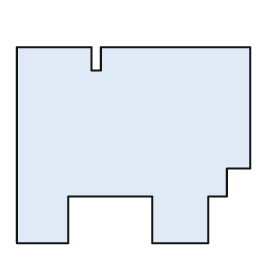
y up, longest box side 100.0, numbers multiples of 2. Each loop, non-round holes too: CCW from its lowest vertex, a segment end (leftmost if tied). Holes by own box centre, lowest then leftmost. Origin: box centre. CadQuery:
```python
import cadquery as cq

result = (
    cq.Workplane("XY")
    .moveTo(-50.0, -42.0)
    .lineTo(-28.0, -42.0)
    .lineTo(-28.0, -22.0)
    .lineTo(8.0, -22.0)
    .lineTo(8.0, -42.0)
    .lineTo(32.0, -42.0)
    .lineTo(32.0, -22.0)
    .lineTo(40.0, -22.0)
    .lineTo(40.0, -10.0)
    .lineTo(50.0, -10.0)
    .lineTo(50.0, 42.0)
    .lineTo(-14.0, 42.0)
    .lineTo(-14.0, 32.0)
    .lineTo(-18.0, 32.0)
    .lineTo(-18.0, 42.0)
    .lineTo(-50.0, 42.0)
    .close()
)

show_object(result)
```